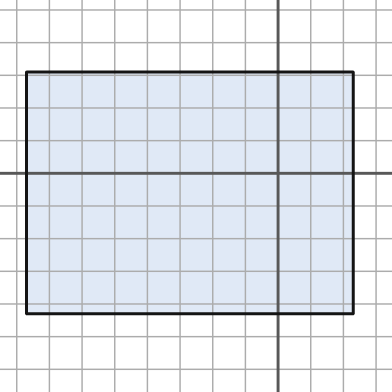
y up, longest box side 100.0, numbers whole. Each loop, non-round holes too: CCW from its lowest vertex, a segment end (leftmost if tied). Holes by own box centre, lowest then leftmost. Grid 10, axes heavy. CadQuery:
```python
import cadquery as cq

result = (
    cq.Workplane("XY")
    .moveTo(-77.0, -43.0)
    .lineTo(23.0, -43.0)
    .lineTo(23.0, 31.0)
    .lineTo(-77.0, 31.0)
    .close()
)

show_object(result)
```